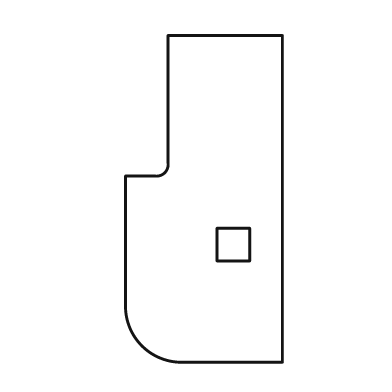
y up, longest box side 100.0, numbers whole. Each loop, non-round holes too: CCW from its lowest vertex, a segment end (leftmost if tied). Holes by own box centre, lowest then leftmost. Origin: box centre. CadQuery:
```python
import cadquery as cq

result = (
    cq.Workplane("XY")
    .moveTo(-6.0, -50.0)
    .lineTo(24.0, -50.0)
    .lineTo(24.0, 50.0)
    .lineTo(-11.0, 50.0)
    .lineTo(-11.0, 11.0)
    .threePointArc((-12.0, 8.0), (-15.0, 7.0))
    .lineTo(-24.0, 7.0)
    .lineTo(-24.0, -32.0)
    .threePointArc((-19.0, -45.0), (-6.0, -50.0))
    .close()
    .moveTo(4.0, -19.0)
    .lineTo(14.0, -19.0)
    .lineTo(14.0, -9.0)
    .lineTo(4.0, -9.0)
    .close()
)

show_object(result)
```